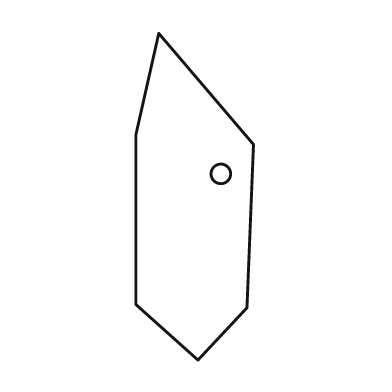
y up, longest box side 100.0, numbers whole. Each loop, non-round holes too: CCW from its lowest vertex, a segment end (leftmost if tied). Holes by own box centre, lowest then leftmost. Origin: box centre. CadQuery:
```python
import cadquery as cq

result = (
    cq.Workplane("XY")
    .moveTo(1.0, -50.0)
    .lineTo(16.0, -34.0)
    .lineTo(18.0, 16.0)
    .lineTo(-11.0, 50.0)
    .lineTo(-18.0, 19.0)
    .lineTo(-18.0, -33.0)
    .close()
    .moveTo(8.0, 7.0)
    .circle(3.0)
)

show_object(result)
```